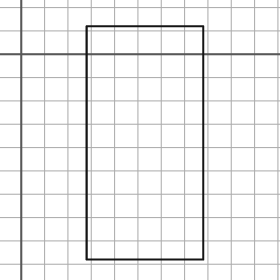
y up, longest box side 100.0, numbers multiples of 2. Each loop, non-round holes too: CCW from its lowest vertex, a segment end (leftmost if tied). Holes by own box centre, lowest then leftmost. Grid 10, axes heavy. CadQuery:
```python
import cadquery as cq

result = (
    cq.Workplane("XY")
    .moveTo(28.0, -88.0)
    .lineTo(78.0, -88.0)
    .lineTo(78.0, 12.0)
    .lineTo(28.0, 12.0)
    .close()
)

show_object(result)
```